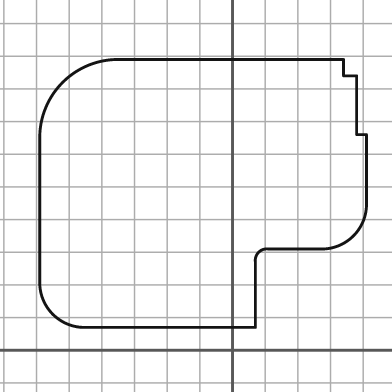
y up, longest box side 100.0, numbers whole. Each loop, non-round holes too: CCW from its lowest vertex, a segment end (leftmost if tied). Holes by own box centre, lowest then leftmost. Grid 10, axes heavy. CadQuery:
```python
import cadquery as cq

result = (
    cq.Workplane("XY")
    .moveTo(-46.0, 7.0)
    .lineTo(7.0, 7.0)
    .lineTo(7.0, 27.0)
    .threePointArc((8.0, 30.0), (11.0, 31.0))
    .lineTo(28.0, 31.0)
    .threePointArc((37.0, 35.0), (41.0, 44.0))
    .lineTo(41.0, 66.0)
    .lineTo(38.0, 66.0)
    .lineTo(38.0, 84.0)
    .lineTo(34.0, 84.0)
    .lineTo(34.0, 89.0)
    .lineTo(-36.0, 89.0)
    .threePointArc((-52.0, 82.0), (-59.0, 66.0))
    .lineTo(-59.0, 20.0)
    .threePointArc((-55.0, 11.0), (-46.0, 7.0))
    .close()
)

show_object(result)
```